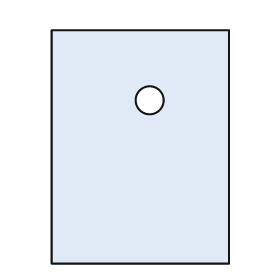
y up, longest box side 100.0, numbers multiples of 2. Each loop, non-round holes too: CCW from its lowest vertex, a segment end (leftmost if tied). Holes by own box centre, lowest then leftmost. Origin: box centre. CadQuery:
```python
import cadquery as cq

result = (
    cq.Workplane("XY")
    .moveTo(-38.0, -50.0)
    .lineTo(38.0, -50.0)
    .lineTo(38.0, 50.0)
    .lineTo(-38.0, 50.0)
    .close()
    .moveTo(4.0, 20.0)
    .circle(6.0)
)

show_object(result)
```